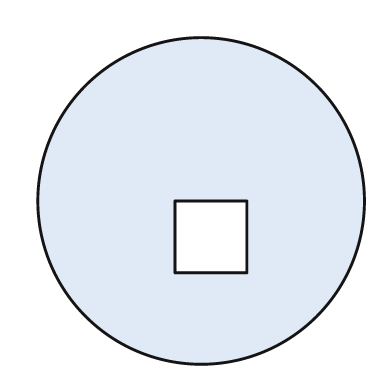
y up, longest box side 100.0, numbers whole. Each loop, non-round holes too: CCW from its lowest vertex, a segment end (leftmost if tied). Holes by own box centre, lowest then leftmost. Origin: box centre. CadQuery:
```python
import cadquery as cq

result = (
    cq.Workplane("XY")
    .moveTo(0.0, 0.0)
    .circle(50.0)
    .moveTo(-8.0, -22.0)
    .lineTo(14.0, -22.0)
    .lineTo(14.0, 0.0)
    .lineTo(-8.0, 0.0)
    .close()
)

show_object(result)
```